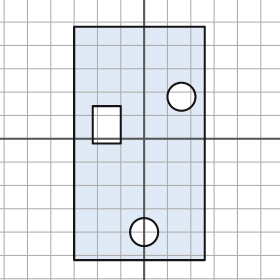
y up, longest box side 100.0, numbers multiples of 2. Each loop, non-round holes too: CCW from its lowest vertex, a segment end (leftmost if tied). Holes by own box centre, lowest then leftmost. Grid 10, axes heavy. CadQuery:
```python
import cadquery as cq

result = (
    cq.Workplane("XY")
    .moveTo(-30.0, -52.0)
    .lineTo(26.0, -52.0)
    .lineTo(26.0, 48.0)
    .lineTo(-30.0, 48.0)
    .close()
    .moveTo(0.0, -40.0)
    .circle(6.0)
    .moveTo(-22.0, -2.0)
    .lineTo(-10.0, -2.0)
    .lineTo(-10.0, 14.0)
    .lineTo(-22.0, 14.0)
    .close()
    .moveTo(16.0, 18.0)
    .circle(6.0)
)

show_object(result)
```